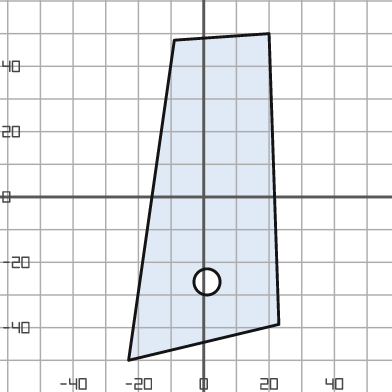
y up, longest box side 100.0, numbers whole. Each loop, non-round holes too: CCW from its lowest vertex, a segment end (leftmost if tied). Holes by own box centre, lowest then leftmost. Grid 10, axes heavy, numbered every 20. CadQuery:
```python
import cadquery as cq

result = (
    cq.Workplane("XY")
    .moveTo(-23.0, -50.0)
    .lineTo(23.0, -39.0)
    .lineTo(20.0, 50.0)
    .lineTo(-9.0, 48.0)
    .close()
    .moveTo(1.0, -26.0)
    .circle(4.0)
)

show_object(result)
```